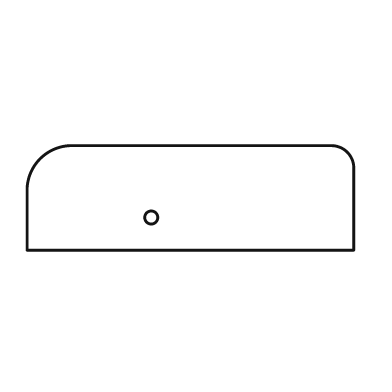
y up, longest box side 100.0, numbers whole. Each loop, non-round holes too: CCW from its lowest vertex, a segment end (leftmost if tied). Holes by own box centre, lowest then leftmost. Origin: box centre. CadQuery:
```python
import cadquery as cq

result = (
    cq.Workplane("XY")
    .moveTo(-50.0, -16.0)
    .lineTo(50.0, -16.0)
    .lineTo(50.0, 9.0)
    .threePointArc((48.0, 14.0), (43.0, 16.0))
    .lineTo(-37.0, 16.0)
    .threePointArc((-46.0, 12.0), (-50.0, 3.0))
    .close()
    .moveTo(-12.0, -6.0)
    .circle(2.0)
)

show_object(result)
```